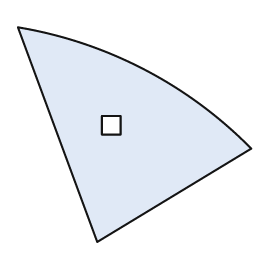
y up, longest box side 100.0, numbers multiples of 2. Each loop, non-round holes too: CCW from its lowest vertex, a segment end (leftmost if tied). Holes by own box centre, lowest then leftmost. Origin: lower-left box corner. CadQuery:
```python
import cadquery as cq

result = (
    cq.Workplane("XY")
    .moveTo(34.0, 0.0)
    .lineTo(100.0, 40.0)
    .threePointArc((54.0, 74.0), (0.0, 92.0))
    .close()
    .moveTo(36.0, 46.0)
    .lineTo(44.0, 46.0)
    .lineTo(44.0, 54.0)
    .lineTo(36.0, 54.0)
    .close()
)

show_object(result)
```